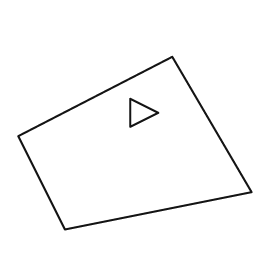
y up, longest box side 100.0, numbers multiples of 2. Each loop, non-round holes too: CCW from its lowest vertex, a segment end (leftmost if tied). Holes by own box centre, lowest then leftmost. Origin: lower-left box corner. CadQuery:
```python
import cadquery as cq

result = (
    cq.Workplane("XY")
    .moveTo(20.0, 0.0)
    .lineTo(100.0, 16.0)
    .lineTo(66.0, 74.0)
    .lineTo(0.0, 40.0)
    .close()
    .moveTo(48.0, 44.0)
    .lineTo(60.0, 50.0)
    .lineTo(48.0, 56.0)
    .close()
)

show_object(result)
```